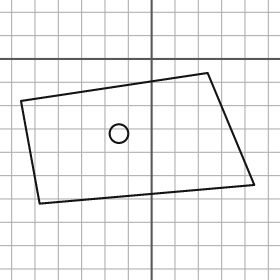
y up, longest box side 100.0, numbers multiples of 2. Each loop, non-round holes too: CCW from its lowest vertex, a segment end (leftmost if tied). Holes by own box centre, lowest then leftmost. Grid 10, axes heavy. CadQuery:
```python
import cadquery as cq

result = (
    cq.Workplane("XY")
    .moveTo(-48.0, -62.0)
    .lineTo(44.0, -54.0)
    .lineTo(24.0, -6.0)
    .lineTo(-56.0, -18.0)
    .close()
    .moveTo(-14.0, -32.0)
    .circle(4.0)
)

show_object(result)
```